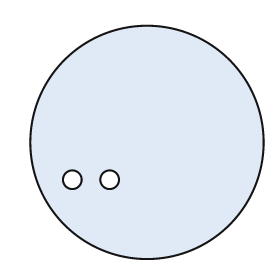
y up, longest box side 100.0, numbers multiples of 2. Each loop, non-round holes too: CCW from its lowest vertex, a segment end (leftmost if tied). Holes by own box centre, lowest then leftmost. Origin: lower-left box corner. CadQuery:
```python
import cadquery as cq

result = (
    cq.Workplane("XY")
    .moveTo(50.0, 50.0)
    .circle(50.0)
    .moveTo(18.0, 34.0)
    .circle(4.0)
    .moveTo(34.0, 34.0)
    .circle(4.0)
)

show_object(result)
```